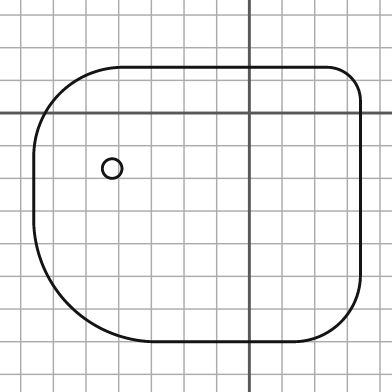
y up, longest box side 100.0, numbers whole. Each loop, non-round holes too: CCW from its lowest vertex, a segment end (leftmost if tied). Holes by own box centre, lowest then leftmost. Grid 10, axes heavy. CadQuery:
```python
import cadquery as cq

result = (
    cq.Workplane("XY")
    .moveTo(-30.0, -70.0)
    .lineTo(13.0, -70.0)
    .threePointArc((28.0, -64.0), (34.0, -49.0))
    .lineTo(34.0, 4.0)
    .threePointArc((31.0, 11.0), (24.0, 14.0))
    .lineTo(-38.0, 14.0)
    .threePointArc((-58.0, 6.0), (-66.0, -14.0))
    .lineTo(-66.0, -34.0)
    .threePointArc((-55.0, -59.0), (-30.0, -70.0))
    .close()
    .moveTo(-42.0, -17.0)
    .circle(3.0)
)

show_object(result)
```